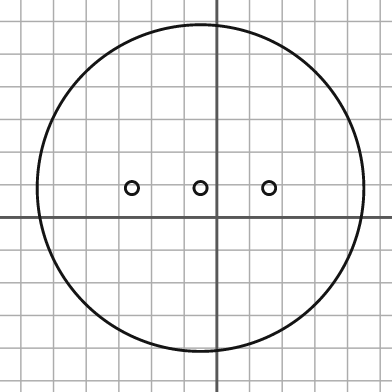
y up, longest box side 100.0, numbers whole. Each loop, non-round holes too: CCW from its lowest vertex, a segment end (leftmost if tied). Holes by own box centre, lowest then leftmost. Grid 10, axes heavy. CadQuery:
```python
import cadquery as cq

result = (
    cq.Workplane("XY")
    .moveTo(-5.0, 9.0)
    .circle(50.0)
    .moveTo(-26.0, 9.0)
    .circle(2.0)
    .moveTo(-5.0, 9.0)
    .circle(2.0)
    .moveTo(16.0, 9.0)
    .circle(2.0)
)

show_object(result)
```